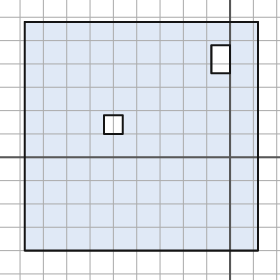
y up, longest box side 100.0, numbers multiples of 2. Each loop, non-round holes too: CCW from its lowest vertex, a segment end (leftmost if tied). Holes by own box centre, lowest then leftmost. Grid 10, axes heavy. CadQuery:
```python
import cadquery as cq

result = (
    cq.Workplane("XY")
    .moveTo(-88.0, -40.0)
    .lineTo(12.0, -40.0)
    .lineTo(12.0, 58.0)
    .lineTo(-88.0, 58.0)
    .close()
    .moveTo(-54.0, 10.0)
    .lineTo(-46.0, 10.0)
    .lineTo(-46.0, 18.0)
    .lineTo(-54.0, 18.0)
    .close()
    .moveTo(-8.0, 36.0)
    .lineTo(0.0, 36.0)
    .lineTo(0.0, 48.0)
    .lineTo(-8.0, 48.0)
    .close()
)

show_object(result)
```